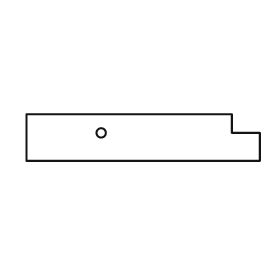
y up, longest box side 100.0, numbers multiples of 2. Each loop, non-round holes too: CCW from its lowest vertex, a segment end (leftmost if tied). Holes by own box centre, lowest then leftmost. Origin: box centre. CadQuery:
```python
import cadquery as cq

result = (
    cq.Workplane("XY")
    .moveTo(-50.0, -10.0)
    .lineTo(50.0, -10.0)
    .lineTo(50.0, 2.0)
    .lineTo(38.0, 2.0)
    .lineTo(38.0, 10.0)
    .lineTo(-50.0, 10.0)
    .close()
    .moveTo(-18.0, 2.0)
    .circle(2.0)
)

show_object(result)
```